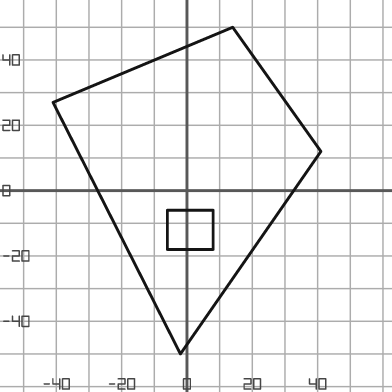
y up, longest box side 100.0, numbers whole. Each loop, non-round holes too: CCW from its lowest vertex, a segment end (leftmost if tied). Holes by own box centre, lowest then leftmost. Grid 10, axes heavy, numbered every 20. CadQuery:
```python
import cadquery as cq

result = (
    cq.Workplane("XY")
    .moveTo(-2.0, -50.0)
    .lineTo(41.0, 12.0)
    .lineTo(14.0, 50.0)
    .lineTo(-41.0, 27.0)
    .close()
    .moveTo(-6.0, -18.0)
    .lineTo(8.0, -18.0)
    .lineTo(8.0, -6.0)
    .lineTo(-6.0, -6.0)
    .close()
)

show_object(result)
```